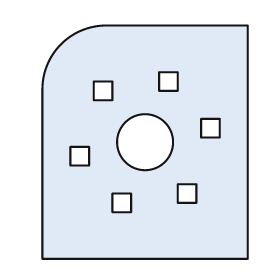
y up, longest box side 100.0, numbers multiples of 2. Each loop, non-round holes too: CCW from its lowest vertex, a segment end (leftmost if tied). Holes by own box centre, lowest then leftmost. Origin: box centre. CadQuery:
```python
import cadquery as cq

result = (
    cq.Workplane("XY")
    .moveTo(-44.0, -50.0)
    .lineTo(44.0, -50.0)
    .lineTo(44.0, 50.0)
    .lineTo(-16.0, 50.0)
    .threePointArc((-36.0, 42.0), (-44.0, 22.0))
    .close()
    .moveTo(-14.0, -30.0)
    .lineTo(-6.0, -30.0)
    .lineTo(-6.0, -22.0)
    .lineTo(-14.0, -22.0)
    .close()
    .moveTo(14.0, -26.0)
    .lineTo(22.0, -26.0)
    .lineTo(22.0, -18.0)
    .lineTo(14.0, -18.0)
    .close()
    .moveTo(-32.0, -10.0)
    .lineTo(-24.0, -10.0)
    .lineTo(-24.0, -2.0)
    .lineTo(-32.0, -2.0)
    .close()
    .moveTo(0.0, 0.0)
    .circle(12.0)
    .moveTo(24.0, 2.0)
    .lineTo(32.0, 2.0)
    .lineTo(32.0, 10.0)
    .lineTo(24.0, 10.0)
    .close()
    .moveTo(-22.0, 18.0)
    .lineTo(-14.0, 18.0)
    .lineTo(-14.0, 26.0)
    .lineTo(-22.0, 26.0)
    .close()
    .moveTo(6.0, 22.0)
    .lineTo(14.0, 22.0)
    .lineTo(14.0, 30.0)
    .lineTo(6.0, 30.0)
    .close()
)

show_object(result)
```